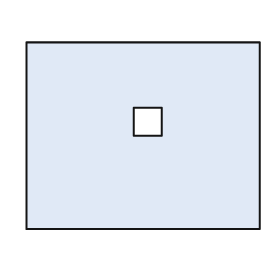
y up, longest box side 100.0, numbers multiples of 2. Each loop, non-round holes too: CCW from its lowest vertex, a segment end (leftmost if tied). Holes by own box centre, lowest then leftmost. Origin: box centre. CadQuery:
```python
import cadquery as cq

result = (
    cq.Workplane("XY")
    .moveTo(-50.0, -40.0)
    .lineTo(50.0, -40.0)
    .lineTo(50.0, 40.0)
    .lineTo(-50.0, 40.0)
    .close()
    .moveTo(-4.0, 0.0)
    .lineTo(8.0, 0.0)
    .lineTo(8.0, 12.0)
    .lineTo(-4.0, 12.0)
    .close()
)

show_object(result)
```